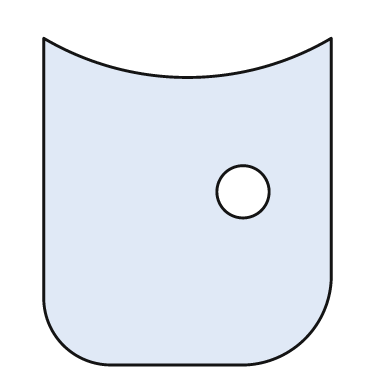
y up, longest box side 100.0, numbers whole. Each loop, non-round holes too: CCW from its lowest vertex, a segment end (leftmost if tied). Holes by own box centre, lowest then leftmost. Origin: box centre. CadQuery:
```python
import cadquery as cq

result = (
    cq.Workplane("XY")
    .moveTo(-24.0, -50.0)
    .lineTo(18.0, -50.0)
    .threePointArc((36.0, -42.0), (44.0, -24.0))
    .lineTo(44.0, 50.0)
    .threePointArc((0.0, 38.0), (-44.0, 50.0))
    .lineTo(-44.0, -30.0)
    .threePointArc((-38.0, -44.0), (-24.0, -50.0))
    .close()
    .moveTo(17.0, 3.0)
    .circle(8.0)
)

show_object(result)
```